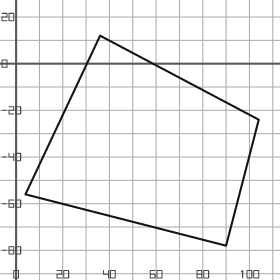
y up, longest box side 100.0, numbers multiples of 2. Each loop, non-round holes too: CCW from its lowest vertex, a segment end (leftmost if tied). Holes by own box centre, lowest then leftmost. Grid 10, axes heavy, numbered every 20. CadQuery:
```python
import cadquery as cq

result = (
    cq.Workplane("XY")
    .moveTo(90.0, -78.0)
    .lineTo(104.0, -24.0)
    .lineTo(36.0, 12.0)
    .lineTo(4.0, -56.0)
    .close()
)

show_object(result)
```